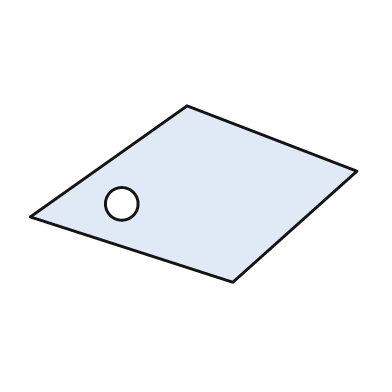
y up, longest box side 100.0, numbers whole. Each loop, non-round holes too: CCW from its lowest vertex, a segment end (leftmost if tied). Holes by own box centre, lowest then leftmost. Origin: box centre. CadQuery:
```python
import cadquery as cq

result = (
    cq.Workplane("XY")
    .moveTo(12.0, -27.0)
    .lineTo(50.0, 7.0)
    .lineTo(-2.0, 27.0)
    .lineTo(-50.0, -7.0)
    .close()
    .moveTo(-22.0, -3.0)
    .circle(5.0)
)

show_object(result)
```